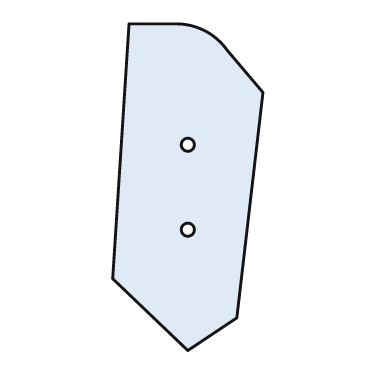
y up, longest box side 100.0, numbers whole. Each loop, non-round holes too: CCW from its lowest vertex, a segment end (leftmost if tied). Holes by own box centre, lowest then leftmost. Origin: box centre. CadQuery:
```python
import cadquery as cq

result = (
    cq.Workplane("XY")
    .moveTo(0.0, -50.0)
    .lineTo(15.0, -40.0)
    .lineTo(23.0, 29.0)
    .lineTo(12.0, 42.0)
    .threePointArc((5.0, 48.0), (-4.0, 50.0))
    .lineTo(-18.0, 50.0)
    .lineTo(-23.0, -28.0)
    .close()
    .moveTo(0.0, -13.0)
    .circle(2.0)
    .moveTo(0.0, 13.0)
    .circle(2.0)
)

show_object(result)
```